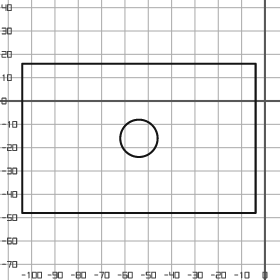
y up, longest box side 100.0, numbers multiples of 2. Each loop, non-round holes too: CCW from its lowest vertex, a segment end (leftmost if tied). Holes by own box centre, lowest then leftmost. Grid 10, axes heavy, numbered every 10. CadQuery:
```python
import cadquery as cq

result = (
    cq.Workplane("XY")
    .moveTo(-104.0, -48.0)
    .lineTo(-4.0, -48.0)
    .lineTo(-4.0, 16.0)
    .lineTo(-104.0, 16.0)
    .close()
    .moveTo(-54.0, -16.0)
    .circle(8.0)
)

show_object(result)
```